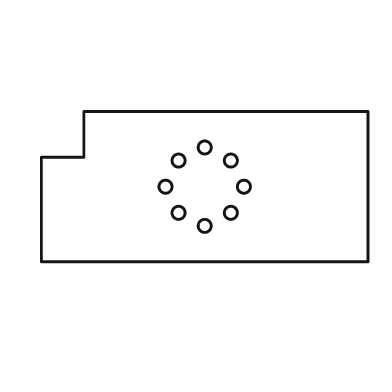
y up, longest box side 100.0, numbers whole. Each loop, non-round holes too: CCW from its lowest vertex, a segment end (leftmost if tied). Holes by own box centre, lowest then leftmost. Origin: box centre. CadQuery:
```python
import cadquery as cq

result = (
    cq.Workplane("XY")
    .moveTo(-50.0, -23.0)
    .lineTo(50.0, -23.0)
    .lineTo(50.0, 23.0)
    .lineTo(-37.0, 23.0)
    .lineTo(-37.0, 9.0)
    .lineTo(-50.0, 9.0)
    .close()
    .moveTo(0.0, -12.0)
    .circle(2.0)
    .moveTo(-8.0, -8.0)
    .circle(2.0)
    .moveTo(8.0, -8.0)
    .circle(2.0)
    .moveTo(-12.0, 0.0)
    .circle(2.0)
    .moveTo(12.0, 0.0)
    .circle(2.0)
    .moveTo(-8.0, 8.0)
    .circle(2.0)
    .moveTo(8.0, 8.0)
    .circle(2.0)
    .moveTo(0.0, 12.0)
    .circle(2.0)
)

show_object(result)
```